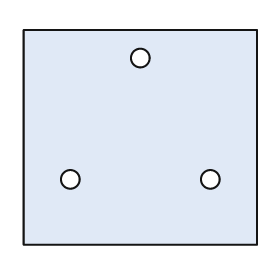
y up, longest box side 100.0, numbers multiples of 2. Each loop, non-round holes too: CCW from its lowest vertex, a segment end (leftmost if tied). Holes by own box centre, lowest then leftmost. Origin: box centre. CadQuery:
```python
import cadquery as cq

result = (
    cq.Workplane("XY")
    .moveTo(-50.0, -46.0)
    .lineTo(50.0, -46.0)
    .lineTo(50.0, 46.0)
    .lineTo(-50.0, 46.0)
    .close()
    .moveTo(-30.0, -18.0)
    .circle(4.0)
    .moveTo(30.0, -18.0)
    .circle(4.0)
    .moveTo(0.0, 34.0)
    .circle(4.0)
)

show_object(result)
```